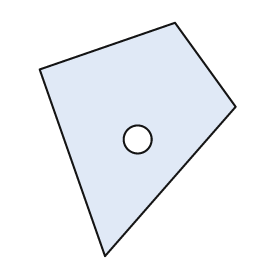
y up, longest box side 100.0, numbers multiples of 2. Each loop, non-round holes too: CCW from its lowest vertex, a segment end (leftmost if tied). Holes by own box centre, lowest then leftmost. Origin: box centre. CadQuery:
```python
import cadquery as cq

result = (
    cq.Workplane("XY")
    .moveTo(-14.0, -50.0)
    .lineTo(42.0, 14.0)
    .lineTo(16.0, 50.0)
    .lineTo(-42.0, 30.0)
    .close()
    .moveTo(0.0, 0.0)
    .circle(6.0)
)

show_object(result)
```